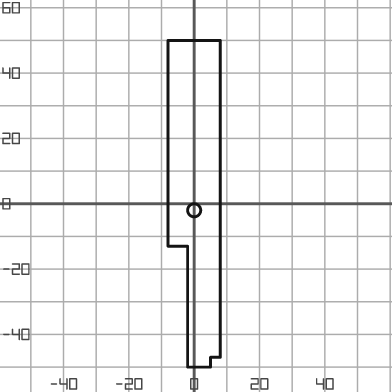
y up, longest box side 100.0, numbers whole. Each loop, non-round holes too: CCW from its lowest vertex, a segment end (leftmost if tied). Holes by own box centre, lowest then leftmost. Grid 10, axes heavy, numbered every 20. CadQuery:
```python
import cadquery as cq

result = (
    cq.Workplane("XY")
    .moveTo(-2.0, -50.0)
    .lineTo(5.0, -50.0)
    .lineTo(5.0, -47.0)
    .lineTo(8.0, -47.0)
    .lineTo(8.0, 50.0)
    .lineTo(-8.0, 50.0)
    .lineTo(-8.0, -13.0)
    .lineTo(-2.0, -13.0)
    .close()
    .moveTo(0.0, -2.0)
    .circle(2.0)
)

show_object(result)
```